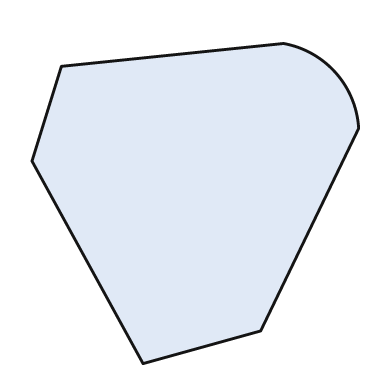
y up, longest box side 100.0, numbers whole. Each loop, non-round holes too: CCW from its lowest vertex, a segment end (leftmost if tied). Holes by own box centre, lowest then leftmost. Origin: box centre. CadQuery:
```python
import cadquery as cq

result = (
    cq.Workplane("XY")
    .moveTo(-16.0, -49.0)
    .lineTo(20.0, -39.0)
    .lineTo(50.0, 23.0)
    .threePointArc((43.0, 40.0), (27.0, 49.0))
    .lineTo(-41.0, 42.0)
    .lineTo(-50.0, 13.0)
    .close()
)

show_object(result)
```